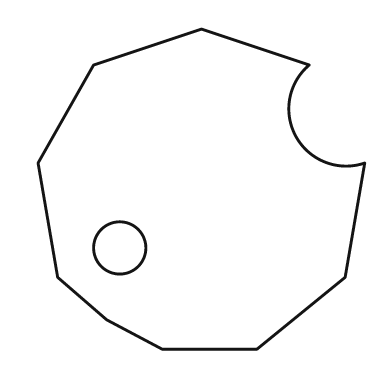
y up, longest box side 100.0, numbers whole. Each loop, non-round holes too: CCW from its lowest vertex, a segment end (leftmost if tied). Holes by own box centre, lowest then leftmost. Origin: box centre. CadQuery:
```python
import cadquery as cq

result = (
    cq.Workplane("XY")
    .moveTo(-12.0, -49.0)
    .lineTo(17.0, -49.0)
    .lineTo(44.0, -27.0)
    .lineTo(50.0, 8.0)
    .threePointArc((29.0, 16.0), (33.0, 38.0))
    .lineTo(0.0, 49.0)
    .lineTo(-33.0, 38.0)
    .lineTo(-50.0, 8.0)
    .lineTo(-44.0, -27.0)
    .lineTo(-29.0, -40.0)
    .close()
    .moveTo(-25.0, -18.0)
    .circle(8.0)
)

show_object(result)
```